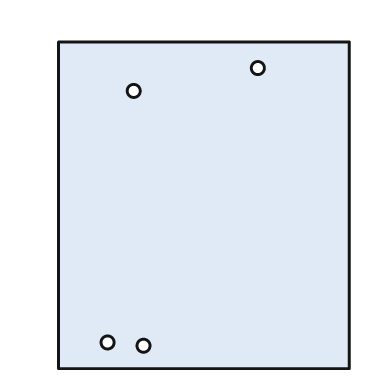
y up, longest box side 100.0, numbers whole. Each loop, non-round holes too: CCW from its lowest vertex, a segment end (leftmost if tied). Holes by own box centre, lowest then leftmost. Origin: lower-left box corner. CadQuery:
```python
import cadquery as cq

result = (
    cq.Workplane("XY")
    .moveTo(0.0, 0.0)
    .lineTo(89.0, 0.0)
    .lineTo(89.0, 100.0)
    .lineTo(0.0, 100.0)
    .close()
    .moveTo(26.0, 7.0)
    .circle(2.0)
    .moveTo(15.0, 8.0)
    .circle(2.0)
    .moveTo(23.0, 85.0)
    .circle(2.0)
    .moveTo(61.0, 92.0)
    .circle(2.0)
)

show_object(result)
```